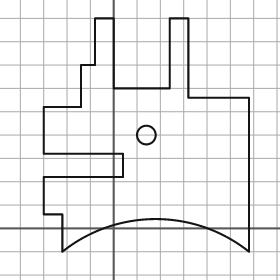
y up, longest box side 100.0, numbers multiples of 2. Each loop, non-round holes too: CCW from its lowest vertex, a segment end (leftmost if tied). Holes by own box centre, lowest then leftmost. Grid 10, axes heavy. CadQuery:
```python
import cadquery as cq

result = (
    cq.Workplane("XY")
    .moveTo(-22.0, -10.0)
    .threePointArc((18.0, 4.0), (58.0, -10.0))
    .lineTo(58.0, 56.0)
    .lineTo(32.0, 56.0)
    .lineTo(32.0, 90.0)
    .lineTo(24.0, 90.0)
    .lineTo(24.0, 60.0)
    .lineTo(0.0, 60.0)
    .lineTo(0.0, 90.0)
    .lineTo(-8.0, 90.0)
    .lineTo(-8.0, 70.0)
    .lineTo(-14.0, 70.0)
    .lineTo(-14.0, 52.0)
    .lineTo(-30.0, 52.0)
    .lineTo(-30.0, 32.0)
    .lineTo(4.0, 32.0)
    .lineTo(4.0, 22.0)
    .lineTo(-30.0, 22.0)
    .lineTo(-30.0, 6.0)
    .lineTo(-22.0, 6.0)
    .close()
    .moveTo(14.0, 40.0)
    .circle(4.0)
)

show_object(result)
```